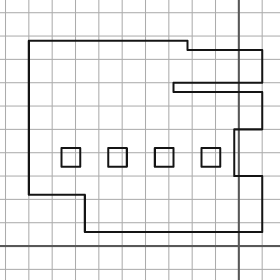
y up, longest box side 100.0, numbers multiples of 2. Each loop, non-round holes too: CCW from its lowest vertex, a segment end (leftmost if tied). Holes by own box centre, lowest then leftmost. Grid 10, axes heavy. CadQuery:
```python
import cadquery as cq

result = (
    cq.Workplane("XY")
    .moveTo(-66.0, 6.0)
    .lineTo(10.0, 6.0)
    .lineTo(10.0, 30.0)
    .lineTo(-2.0, 30.0)
    .lineTo(-2.0, 50.0)
    .lineTo(10.0, 50.0)
    .lineTo(10.0, 66.0)
    .lineTo(-28.0, 66.0)
    .lineTo(-28.0, 70.0)
    .lineTo(10.0, 70.0)
    .lineTo(10.0, 84.0)
    .lineTo(-22.0, 84.0)
    .lineTo(-22.0, 88.0)
    .lineTo(-90.0, 88.0)
    .lineTo(-90.0, 22.0)
    .lineTo(-66.0, 22.0)
    .close()
    .moveTo(-76.0, 34.0)
    .lineTo(-68.0, 34.0)
    .lineTo(-68.0, 42.0)
    .lineTo(-76.0, 42.0)
    .close()
    .moveTo(-56.0, 34.0)
    .lineTo(-48.0, 34.0)
    .lineTo(-48.0, 42.0)
    .lineTo(-56.0, 42.0)
    .close()
    .moveTo(-36.0, 34.0)
    .lineTo(-28.0, 34.0)
    .lineTo(-28.0, 42.0)
    .lineTo(-36.0, 42.0)
    .close()
    .moveTo(-16.0, 34.0)
    .lineTo(-8.0, 34.0)
    .lineTo(-8.0, 42.0)
    .lineTo(-16.0, 42.0)
    .close()
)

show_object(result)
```